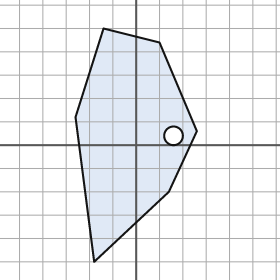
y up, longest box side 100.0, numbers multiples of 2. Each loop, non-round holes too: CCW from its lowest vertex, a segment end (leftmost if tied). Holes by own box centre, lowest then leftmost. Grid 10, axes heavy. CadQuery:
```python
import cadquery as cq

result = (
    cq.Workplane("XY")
    .moveTo(-18.0, -50.0)
    .lineTo(14.0, -20.0)
    .lineTo(26.0, 6.0)
    .lineTo(10.0, 44.0)
    .lineTo(-14.0, 50.0)
    .lineTo(-26.0, 12.0)
    .close()
    .moveTo(16.0, 4.0)
    .circle(4.0)
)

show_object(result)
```